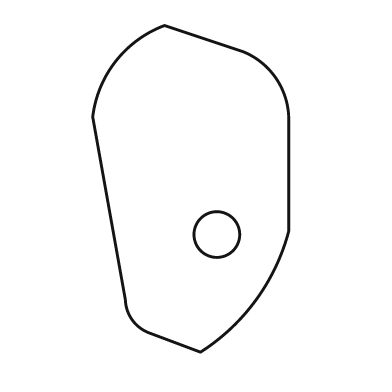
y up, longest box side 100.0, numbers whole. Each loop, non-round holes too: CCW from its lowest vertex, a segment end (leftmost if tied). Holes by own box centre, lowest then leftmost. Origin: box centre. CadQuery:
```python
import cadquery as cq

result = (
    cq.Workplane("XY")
    .moveTo(3.0, -50.0)
    .threePointArc((20.0, -34.0), (30.0, -13.0))
    .lineTo(30.0, 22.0)
    .threePointArc((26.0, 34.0), (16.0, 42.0))
    .lineTo(-8.0, 50.0)
    .threePointArc((-23.0, 39.0), (-30.0, 22.0))
    .lineTo(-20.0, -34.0)
    .threePointArc((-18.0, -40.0), (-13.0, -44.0))
    .close()
    .moveTo(8.0, -14.0)
    .circle(7.0)
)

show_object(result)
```